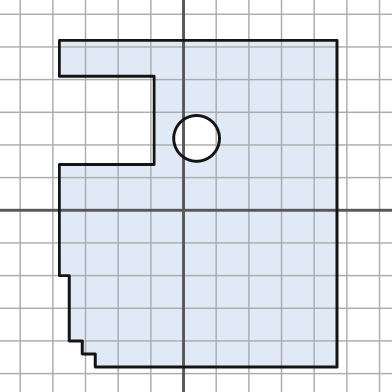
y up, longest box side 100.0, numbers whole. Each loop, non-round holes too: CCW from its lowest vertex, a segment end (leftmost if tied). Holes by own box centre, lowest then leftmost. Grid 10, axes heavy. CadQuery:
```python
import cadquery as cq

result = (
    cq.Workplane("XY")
    .moveTo(-27.0, -48.0)
    .lineTo(47.0, -48.0)
    .lineTo(47.0, 52.0)
    .lineTo(-38.0, 52.0)
    .lineTo(-38.0, 41.0)
    .lineTo(-9.0, 41.0)
    .lineTo(-9.0, 14.0)
    .lineTo(-38.0, 14.0)
    .lineTo(-38.0, -20.0)
    .lineTo(-35.0, -20.0)
    .lineTo(-35.0, -40.0)
    .lineTo(-31.0, -40.0)
    .lineTo(-31.0, -44.0)
    .lineTo(-27.0, -44.0)
    .close()
    .moveTo(4.0, 22.0)
    .circle(7.0)
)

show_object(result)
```